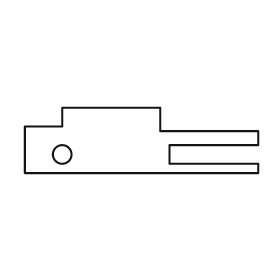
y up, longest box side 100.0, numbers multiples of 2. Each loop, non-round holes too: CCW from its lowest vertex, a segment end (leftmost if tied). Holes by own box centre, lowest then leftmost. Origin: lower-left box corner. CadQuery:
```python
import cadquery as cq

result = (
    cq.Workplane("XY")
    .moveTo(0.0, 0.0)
    .lineTo(100.0, 0.0)
    .lineTo(100.0, 4.0)
    .lineTo(62.0, 4.0)
    .lineTo(62.0, 12.0)
    .lineTo(100.0, 12.0)
    .lineTo(100.0, 18.0)
    .lineTo(58.0, 18.0)
    .lineTo(58.0, 28.0)
    .lineTo(16.0, 28.0)
    .lineTo(16.0, 20.0)
    .lineTo(0.0, 20.0)
    .close()
    .moveTo(16.0, 8.0)
    .circle(4.0)
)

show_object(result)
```